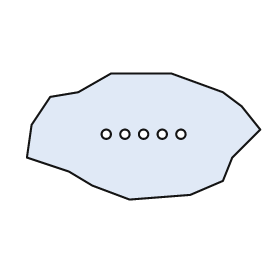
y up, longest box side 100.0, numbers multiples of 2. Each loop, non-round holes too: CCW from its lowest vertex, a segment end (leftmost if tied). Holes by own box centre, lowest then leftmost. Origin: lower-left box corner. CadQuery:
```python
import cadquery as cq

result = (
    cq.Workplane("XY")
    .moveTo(44.0, 0.0)
    .lineTo(70.0, 2.0)
    .lineTo(84.0, 8.0)
    .lineTo(88.0, 18.0)
    .lineTo(100.0, 30.0)
    .lineTo(92.0, 40.0)
    .lineTo(84.0, 46.0)
    .lineTo(62.0, 54.0)
    .lineTo(36.0, 54.0)
    .lineTo(22.0, 46.0)
    .lineTo(10.0, 44.0)
    .lineTo(2.0, 32.0)
    .lineTo(0.0, 18.0)
    .lineTo(18.0, 12.0)
    .lineTo(28.0, 6.0)
    .close()
    .moveTo(34.0, 28.0)
    .circle(2.0)
    .moveTo(42.0, 28.0)
    .circle(2.0)
    .moveTo(50.0, 28.0)
    .circle(2.0)
    .moveTo(58.0, 28.0)
    .circle(2.0)
    .moveTo(66.0, 28.0)
    .circle(2.0)
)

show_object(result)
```